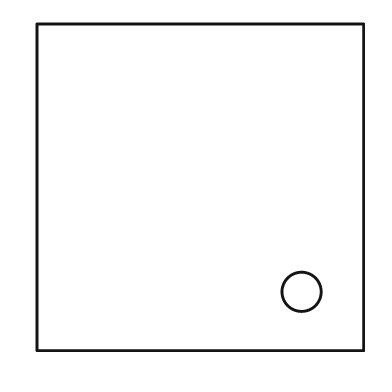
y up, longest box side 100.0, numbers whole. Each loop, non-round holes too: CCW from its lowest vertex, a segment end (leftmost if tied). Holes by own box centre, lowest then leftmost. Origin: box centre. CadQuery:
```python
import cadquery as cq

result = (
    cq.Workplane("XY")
    .moveTo(-50.0, -50.0)
    .lineTo(50.0, -50.0)
    .lineTo(50.0, 50.0)
    .lineTo(-50.0, 50.0)
    .close()
    .moveTo(31.0, -32.0)
    .circle(6.0)
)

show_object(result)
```